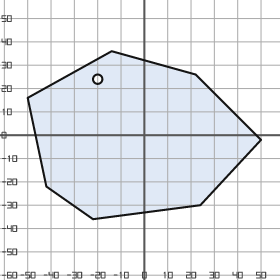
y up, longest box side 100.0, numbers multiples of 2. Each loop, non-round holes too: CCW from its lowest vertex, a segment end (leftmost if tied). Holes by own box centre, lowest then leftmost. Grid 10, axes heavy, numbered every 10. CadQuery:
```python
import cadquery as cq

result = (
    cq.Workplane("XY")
    .moveTo(-22.0, -36.0)
    .lineTo(24.0, -30.0)
    .lineTo(50.0, -2.0)
    .lineTo(22.0, 26.0)
    .lineTo(-14.0, 36.0)
    .lineTo(-50.0, 16.0)
    .lineTo(-42.0, -22.0)
    .close()
    .moveTo(-20.0, 24.0)
    .circle(2.0)
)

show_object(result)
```